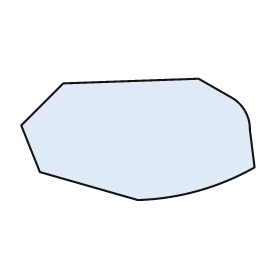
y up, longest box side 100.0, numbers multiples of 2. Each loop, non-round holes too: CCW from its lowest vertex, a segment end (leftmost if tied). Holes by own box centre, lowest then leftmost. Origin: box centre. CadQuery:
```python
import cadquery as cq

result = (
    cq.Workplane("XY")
    .moveTo(0.0, -26.0)
    .threePointArc((26.0, -22.0), (50.0, -12.0))
    .lineTo(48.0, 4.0)
    .threePointArc((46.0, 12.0), (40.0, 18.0))
    .lineTo(26.0, 26.0)
    .lineTo(-32.0, 24.0)
    .lineTo(-50.0, 6.0)
    .lineTo(-42.0, -14.0)
    .close()
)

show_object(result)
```